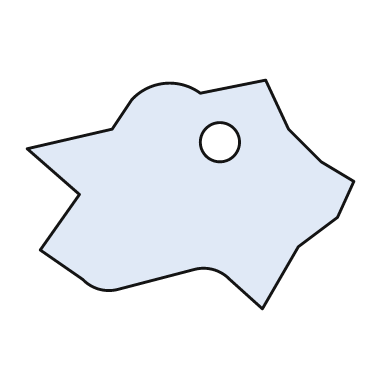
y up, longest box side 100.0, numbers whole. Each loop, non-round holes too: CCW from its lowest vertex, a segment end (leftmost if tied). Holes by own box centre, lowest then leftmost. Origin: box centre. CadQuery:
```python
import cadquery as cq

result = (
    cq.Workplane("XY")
    .moveTo(22.0, -35.0)
    .lineTo(33.0, -16.0)
    .lineTo(45.0, -7.0)
    .lineTo(50.0, 4.0)
    .lineTo(40.0, 10.0)
    .lineTo(30.0, 20.0)
    .lineTo(23.0, 35.0)
    .lineTo(3.0, 31.0)
    .threePointArc((-8.0, 34.0), (-18.0, 29.0))
    .lineTo(-24.0, 20.0)
    .lineTo(-50.0, 14.0)
    .lineTo(-34.0, 0.0)
    .lineTo(-46.0, -17.0)
    .lineTo(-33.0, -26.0)
    .threePointArc((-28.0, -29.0), (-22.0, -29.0))
    .lineTo(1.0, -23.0)
    .threePointArc((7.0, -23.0), (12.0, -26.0))
    .close()
    .moveTo(9.0, 16.0)
    .circle(6.0)
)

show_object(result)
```